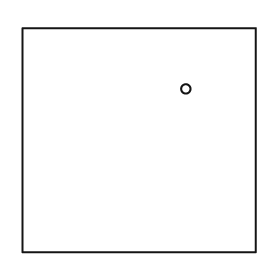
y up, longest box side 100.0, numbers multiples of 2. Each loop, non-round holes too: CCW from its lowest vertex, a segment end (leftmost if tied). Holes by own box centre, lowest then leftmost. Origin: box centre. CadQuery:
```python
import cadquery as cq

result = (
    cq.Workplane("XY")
    .moveTo(-50.0, -48.0)
    .lineTo(50.0, -48.0)
    .lineTo(50.0, 48.0)
    .lineTo(-50.0, 48.0)
    .close()
    .moveTo(20.0, 22.0)
    .circle(2.0)
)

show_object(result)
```